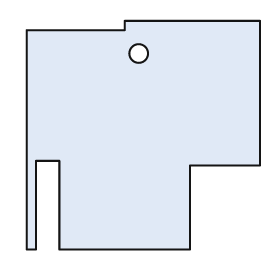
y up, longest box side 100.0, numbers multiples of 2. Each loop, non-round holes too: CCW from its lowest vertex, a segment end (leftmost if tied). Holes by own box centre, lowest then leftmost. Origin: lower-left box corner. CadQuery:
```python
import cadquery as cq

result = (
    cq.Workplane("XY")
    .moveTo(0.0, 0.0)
    .lineTo(4.0, 0.0)
    .lineTo(4.0, 38.0)
    .lineTo(14.0, 38.0)
    .lineTo(14.0, 0.0)
    .lineTo(70.0, 0.0)
    .lineTo(70.0, 36.0)
    .lineTo(100.0, 36.0)
    .lineTo(100.0, 98.0)
    .lineTo(42.0, 98.0)
    .lineTo(42.0, 94.0)
    .lineTo(0.0, 94.0)
    .close()
    .moveTo(48.0, 84.0)
    .circle(4.0)
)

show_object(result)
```